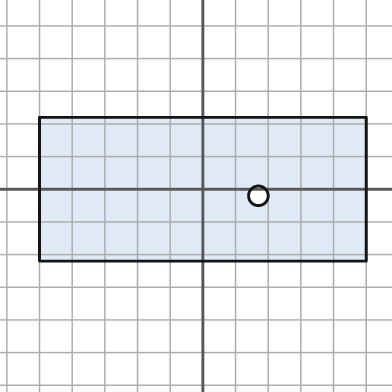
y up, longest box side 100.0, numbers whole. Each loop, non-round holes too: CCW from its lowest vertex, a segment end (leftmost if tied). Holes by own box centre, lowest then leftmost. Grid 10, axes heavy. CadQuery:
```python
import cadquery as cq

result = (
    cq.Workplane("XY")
    .moveTo(-50.0, -22.0)
    .lineTo(50.0, -22.0)
    .lineTo(50.0, 22.0)
    .lineTo(-50.0, 22.0)
    .close()
    .moveTo(17.0, -2.0)
    .circle(3.0)
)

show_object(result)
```